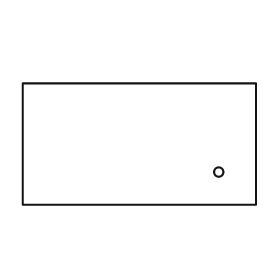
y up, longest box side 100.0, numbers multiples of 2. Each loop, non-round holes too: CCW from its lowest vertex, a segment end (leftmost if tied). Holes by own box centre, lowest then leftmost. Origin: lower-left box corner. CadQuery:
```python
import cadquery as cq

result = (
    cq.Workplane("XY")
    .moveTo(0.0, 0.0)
    .lineTo(100.0, 0.0)
    .lineTo(100.0, 52.0)
    .lineTo(0.0, 52.0)
    .close()
    .moveTo(84.0, 14.0)
    .circle(2.0)
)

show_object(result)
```